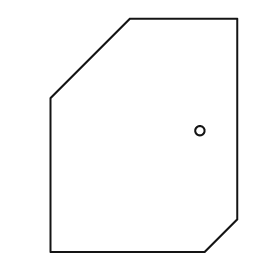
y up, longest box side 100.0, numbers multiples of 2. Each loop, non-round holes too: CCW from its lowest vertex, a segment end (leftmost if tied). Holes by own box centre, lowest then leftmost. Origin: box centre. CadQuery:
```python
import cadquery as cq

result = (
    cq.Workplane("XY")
    .moveTo(-40.0, -50.0)
    .lineTo(26.0, -50.0)
    .lineTo(40.0, -36.0)
    .lineTo(40.0, 50.0)
    .lineTo(-6.0, 50.0)
    .lineTo(-40.0, 16.0)
    .close()
    .moveTo(24.0, 2.0)
    .circle(2.0)
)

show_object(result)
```